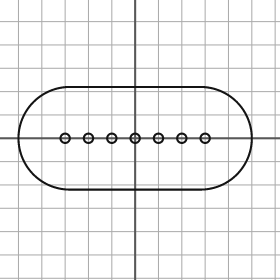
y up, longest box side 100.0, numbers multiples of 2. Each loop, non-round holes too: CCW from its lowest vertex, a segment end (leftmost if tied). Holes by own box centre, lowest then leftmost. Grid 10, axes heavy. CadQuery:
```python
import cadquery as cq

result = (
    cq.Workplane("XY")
    .moveTo(-28.0, -22.0)
    .lineTo(28.0, -22.0)
    .threePointArc((50.0, 0.0), (28.0, 22.0))
    .lineTo(-28.0, 22.0)
    .threePointArc((-50.0, 0.0), (-28.0, -22.0))
    .close()
    .moveTo(-30.0, 0.0)
    .circle(2.0)
    .moveTo(-20.0, 0.0)
    .circle(2.0)
    .moveTo(-10.0, 0.0)
    .circle(2.0)
    .moveTo(0.0, 0.0)
    .circle(2.0)
    .moveTo(10.0, 0.0)
    .circle(2.0)
    .moveTo(20.0, 0.0)
    .circle(2.0)
    .moveTo(30.0, 0.0)
    .circle(2.0)
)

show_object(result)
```